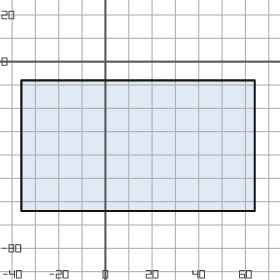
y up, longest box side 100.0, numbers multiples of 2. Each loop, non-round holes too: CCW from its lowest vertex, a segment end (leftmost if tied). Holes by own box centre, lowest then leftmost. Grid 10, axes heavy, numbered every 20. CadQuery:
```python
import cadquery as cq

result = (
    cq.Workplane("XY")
    .moveTo(-36.0, -64.0)
    .lineTo(64.0, -64.0)
    .lineTo(64.0, -8.0)
    .lineTo(-36.0, -8.0)
    .close()
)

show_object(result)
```